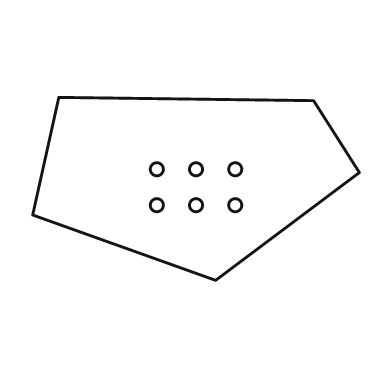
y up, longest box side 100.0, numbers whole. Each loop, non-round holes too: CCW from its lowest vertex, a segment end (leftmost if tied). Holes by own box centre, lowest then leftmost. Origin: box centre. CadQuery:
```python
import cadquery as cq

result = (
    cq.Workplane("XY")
    .moveTo(6.0, -28.0)
    .lineTo(50.0, 5.0)
    .lineTo(36.0, 27.0)
    .lineTo(-42.0, 28.0)
    .lineTo(-50.0, -8.0)
    .close()
    .moveTo(-12.0, -5.0)
    .circle(2.0)
    .moveTo(0.0, -5.0)
    .circle(2.0)
    .moveTo(12.0, -5.0)
    .circle(2.0)
    .moveTo(-12.0, 6.0)
    .circle(2.0)
    .moveTo(0.0, 6.0)
    .circle(2.0)
    .moveTo(12.0, 6.0)
    .circle(2.0)
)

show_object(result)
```